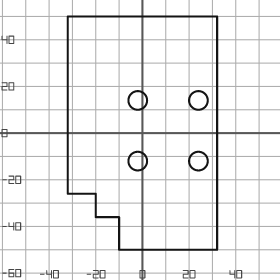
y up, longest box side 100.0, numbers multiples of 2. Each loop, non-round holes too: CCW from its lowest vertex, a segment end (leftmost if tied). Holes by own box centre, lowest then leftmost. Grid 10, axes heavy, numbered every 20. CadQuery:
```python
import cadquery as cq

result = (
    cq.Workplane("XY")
    .moveTo(-10.0, -50.0)
    .lineTo(32.0, -50.0)
    .lineTo(32.0, 50.0)
    .lineTo(-32.0, 50.0)
    .lineTo(-32.0, -26.0)
    .lineTo(-20.0, -26.0)
    .lineTo(-20.0, -36.0)
    .lineTo(-10.0, -36.0)
    .close()
    .moveTo(-2.0, -12.0)
    .circle(4.0)
    .moveTo(24.0, -12.0)
    .circle(4.0)
    .moveTo(-2.0, 14.0)
    .circle(4.0)
    .moveTo(24.0, 14.0)
    .circle(4.0)
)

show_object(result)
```